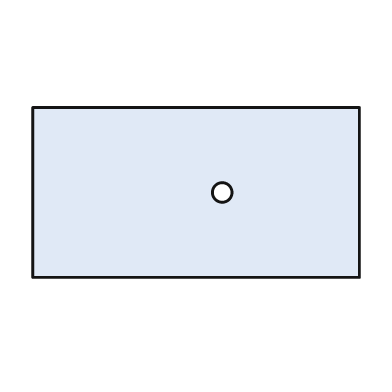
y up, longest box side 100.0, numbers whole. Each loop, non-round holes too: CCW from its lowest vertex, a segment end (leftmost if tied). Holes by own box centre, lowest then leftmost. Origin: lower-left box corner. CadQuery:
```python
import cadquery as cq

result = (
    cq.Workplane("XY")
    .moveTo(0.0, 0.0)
    .lineTo(100.0, 0.0)
    .lineTo(100.0, 52.0)
    .lineTo(0.0, 52.0)
    .close()
    .moveTo(58.0, 26.0)
    .circle(3.0)
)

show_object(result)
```